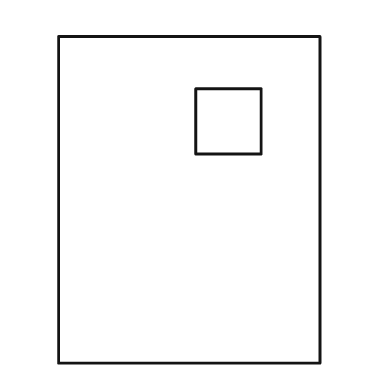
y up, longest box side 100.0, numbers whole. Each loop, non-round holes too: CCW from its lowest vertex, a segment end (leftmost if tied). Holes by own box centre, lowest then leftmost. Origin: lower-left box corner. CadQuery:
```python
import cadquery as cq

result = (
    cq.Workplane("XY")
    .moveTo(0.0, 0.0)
    .lineTo(80.0, 0.0)
    .lineTo(80.0, 100.0)
    .lineTo(0.0, 100.0)
    .close()
    .moveTo(42.0, 64.0)
    .lineTo(62.0, 64.0)
    .lineTo(62.0, 84.0)
    .lineTo(42.0, 84.0)
    .close()
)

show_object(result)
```